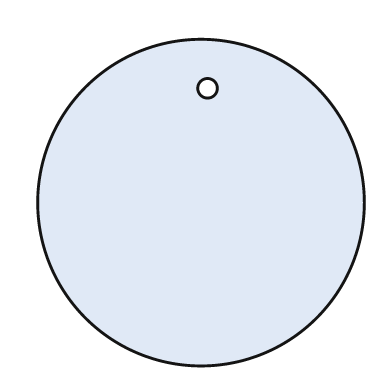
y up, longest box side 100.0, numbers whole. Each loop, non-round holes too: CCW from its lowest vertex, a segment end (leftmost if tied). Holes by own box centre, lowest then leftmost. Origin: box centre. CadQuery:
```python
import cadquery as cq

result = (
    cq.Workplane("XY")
    .moveTo(0.0, 0.0)
    .circle(50.0)
    .moveTo(2.0, 35.0)
    .circle(3.0)
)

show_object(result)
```